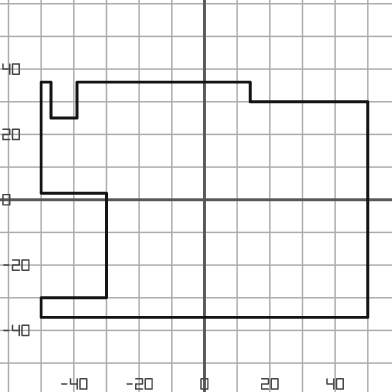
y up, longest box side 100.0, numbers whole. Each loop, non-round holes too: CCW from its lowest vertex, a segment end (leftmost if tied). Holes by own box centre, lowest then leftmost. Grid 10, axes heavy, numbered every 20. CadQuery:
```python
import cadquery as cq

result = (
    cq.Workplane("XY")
    .moveTo(-50.0, -36.0)
    .lineTo(50.0, -36.0)
    .lineTo(50.0, 30.0)
    .lineTo(14.0, 30.0)
    .lineTo(14.0, 36.0)
    .lineTo(-39.0, 36.0)
    .lineTo(-39.0, 25.0)
    .lineTo(-47.0, 25.0)
    .lineTo(-47.0, 36.0)
    .lineTo(-50.0, 36.0)
    .lineTo(-50.0, 2.0)
    .lineTo(-30.0, 2.0)
    .lineTo(-30.0, -30.0)
    .lineTo(-50.0, -30.0)
    .close()
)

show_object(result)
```